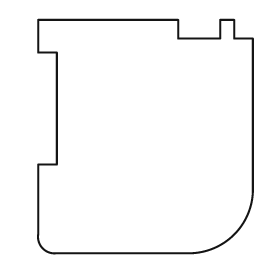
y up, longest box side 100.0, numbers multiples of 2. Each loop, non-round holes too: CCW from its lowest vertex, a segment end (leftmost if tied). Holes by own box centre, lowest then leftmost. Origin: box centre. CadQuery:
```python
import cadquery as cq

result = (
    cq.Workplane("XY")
    .moveTo(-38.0, -50.0)
    .lineTo(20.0, -50.0)
    .threePointArc((38.0, -42.0), (46.0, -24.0))
    .lineTo(46.0, 42.0)
    .lineTo(38.0, 42.0)
    .lineTo(38.0, 50.0)
    .lineTo(32.0, 50.0)
    .lineTo(32.0, 42.0)
    .lineTo(14.0, 42.0)
    .lineTo(14.0, 50.0)
    .lineTo(-46.0, 50.0)
    .lineTo(-46.0, 36.0)
    .lineTo(-38.0, 36.0)
    .lineTo(-38.0, -12.0)
    .lineTo(-46.0, -12.0)
    .lineTo(-46.0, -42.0)
    .threePointArc((-44.0, -48.0), (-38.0, -50.0))
    .close()
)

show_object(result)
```